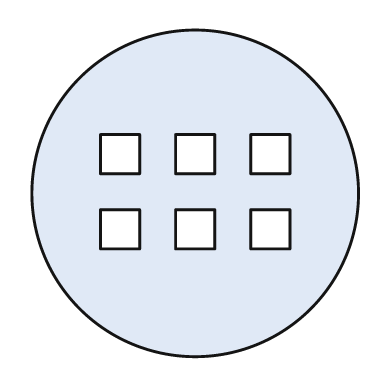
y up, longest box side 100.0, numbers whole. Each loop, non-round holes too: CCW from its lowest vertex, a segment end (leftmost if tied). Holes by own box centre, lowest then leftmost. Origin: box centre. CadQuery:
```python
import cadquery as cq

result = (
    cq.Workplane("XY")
    .moveTo(0.0, 0.0)
    .circle(50.0)
    .moveTo(-29.0, -17.0)
    .lineTo(-17.0, -17.0)
    .lineTo(-17.0, -5.0)
    .lineTo(-29.0, -5.0)
    .close()
    .moveTo(-6.0, -17.0)
    .lineTo(6.0, -17.0)
    .lineTo(6.0, -5.0)
    .lineTo(-6.0, -5.0)
    .close()
    .moveTo(17.0, -17.0)
    .lineTo(29.0, -17.0)
    .lineTo(29.0, -5.0)
    .lineTo(17.0, -5.0)
    .close()
    .moveTo(-29.0, 6.0)
    .lineTo(-17.0, 6.0)
    .lineTo(-17.0, 18.0)
    .lineTo(-29.0, 18.0)
    .close()
    .moveTo(-6.0, 6.0)
    .lineTo(6.0, 6.0)
    .lineTo(6.0, 18.0)
    .lineTo(-6.0, 18.0)
    .close()
    .moveTo(17.0, 6.0)
    .lineTo(29.0, 6.0)
    .lineTo(29.0, 18.0)
    .lineTo(17.0, 18.0)
    .close()
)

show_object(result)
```